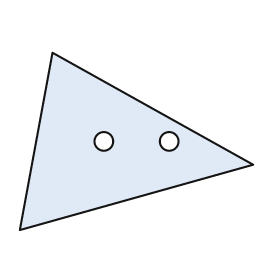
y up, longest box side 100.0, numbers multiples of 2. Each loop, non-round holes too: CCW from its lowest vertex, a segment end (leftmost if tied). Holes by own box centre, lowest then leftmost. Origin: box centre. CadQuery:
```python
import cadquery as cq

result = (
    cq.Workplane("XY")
    .moveTo(-50.0, -38.0)
    .lineTo(50.0, -10.0)
    .lineTo(-36.0, 38.0)
    .close()
    .moveTo(-14.0, 0.0)
    .circle(4.0)
    .moveTo(14.0, 0.0)
    .circle(4.0)
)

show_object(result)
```